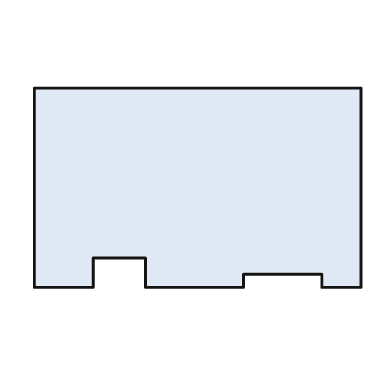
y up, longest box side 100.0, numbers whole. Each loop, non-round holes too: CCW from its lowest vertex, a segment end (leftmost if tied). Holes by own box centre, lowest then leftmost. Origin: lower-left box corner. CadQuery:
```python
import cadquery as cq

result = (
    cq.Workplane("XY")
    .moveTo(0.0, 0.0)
    .lineTo(18.0, 0.0)
    .lineTo(18.0, 9.0)
    .lineTo(34.0, 9.0)
    .lineTo(34.0, 0.0)
    .lineTo(64.0, 0.0)
    .lineTo(64.0, 4.0)
    .lineTo(88.0, 4.0)
    .lineTo(88.0, 0.0)
    .lineTo(100.0, 0.0)
    .lineTo(100.0, 61.0)
    .lineTo(0.0, 61.0)
    .close()
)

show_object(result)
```